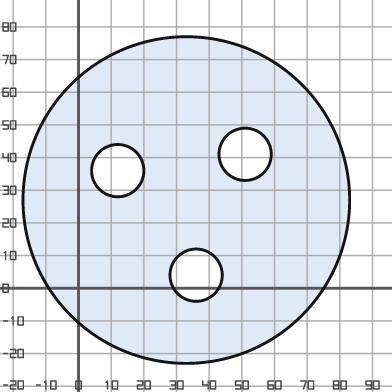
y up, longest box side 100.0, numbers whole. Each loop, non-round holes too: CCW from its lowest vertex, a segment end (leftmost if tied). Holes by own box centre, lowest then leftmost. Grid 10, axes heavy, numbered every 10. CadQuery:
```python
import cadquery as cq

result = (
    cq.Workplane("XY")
    .moveTo(33.0, 27.0)
    .circle(50.0)
    .moveTo(36.0, 4.0)
    .circle(8.0)
    .moveTo(12.0, 36.0)
    .circle(8.0)
    .moveTo(51.0, 41.0)
    .circle(8.0)
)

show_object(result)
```